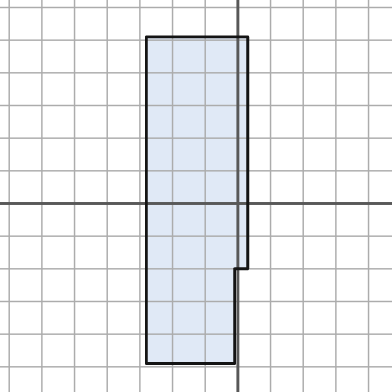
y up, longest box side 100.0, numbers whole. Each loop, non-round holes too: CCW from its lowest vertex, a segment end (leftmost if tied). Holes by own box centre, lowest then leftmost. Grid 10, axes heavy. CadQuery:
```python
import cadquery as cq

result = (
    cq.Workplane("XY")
    .moveTo(-28.0, -49.0)
    .lineTo(-1.0, -49.0)
    .lineTo(-1.0, -20.0)
    .lineTo(3.0, -20.0)
    .lineTo(3.0, 51.0)
    .lineTo(-28.0, 51.0)
    .close()
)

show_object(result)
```